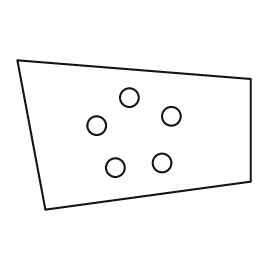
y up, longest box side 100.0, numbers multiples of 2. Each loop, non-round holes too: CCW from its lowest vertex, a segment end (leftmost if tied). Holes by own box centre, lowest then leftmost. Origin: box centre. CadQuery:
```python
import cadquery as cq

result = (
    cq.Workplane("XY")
    .moveTo(-38.0, -32.0)
    .lineTo(50.0, -20.0)
    .lineTo(50.0, 24.0)
    .lineTo(-50.0, 32.0)
    .close()
    .moveTo(-8.0, -14.0)
    .circle(4.0)
    .moveTo(12.0, -12.0)
    .circle(4.0)
    .moveTo(-16.0, 4.0)
    .circle(4.0)
    .moveTo(16.0, 8.0)
    .circle(4.0)
    .moveTo(-2.0, 16.0)
    .circle(4.0)
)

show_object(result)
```